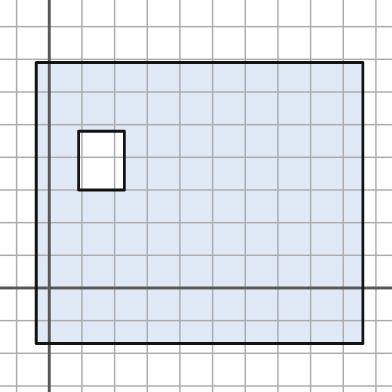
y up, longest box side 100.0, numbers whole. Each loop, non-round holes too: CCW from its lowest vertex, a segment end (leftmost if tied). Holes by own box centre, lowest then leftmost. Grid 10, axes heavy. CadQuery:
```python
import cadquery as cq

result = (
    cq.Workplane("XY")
    .moveTo(-4.0, -17.0)
    .lineTo(96.0, -17.0)
    .lineTo(96.0, 69.0)
    .lineTo(-4.0, 69.0)
    .close()
    .moveTo(9.0, 30.0)
    .lineTo(23.0, 30.0)
    .lineTo(23.0, 48.0)
    .lineTo(9.0, 48.0)
    .close()
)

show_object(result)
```